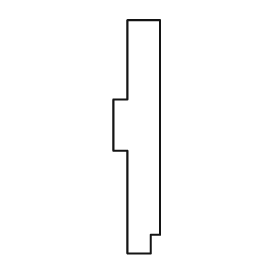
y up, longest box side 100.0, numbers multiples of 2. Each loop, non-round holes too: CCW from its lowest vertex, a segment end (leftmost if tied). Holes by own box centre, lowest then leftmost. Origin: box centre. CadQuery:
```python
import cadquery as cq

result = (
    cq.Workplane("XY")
    .moveTo(-4.0, -50.0)
    .lineTo(6.0, -50.0)
    .lineTo(6.0, -42.0)
    .lineTo(10.0, -42.0)
    .lineTo(10.0, 50.0)
    .lineTo(-4.0, 50.0)
    .lineTo(-4.0, 16.0)
    .lineTo(-10.0, 16.0)
    .lineTo(-10.0, -6.0)
    .lineTo(-4.0, -6.0)
    .close()
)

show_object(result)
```